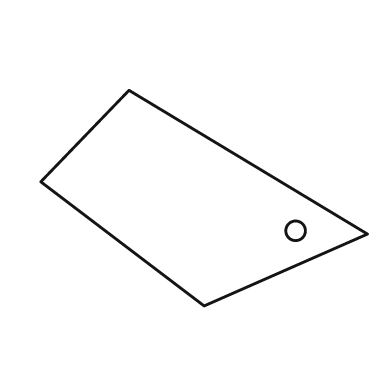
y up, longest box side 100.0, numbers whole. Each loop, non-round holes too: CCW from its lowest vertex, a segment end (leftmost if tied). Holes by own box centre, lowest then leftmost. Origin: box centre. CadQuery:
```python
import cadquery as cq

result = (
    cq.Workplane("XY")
    .moveTo(0.0, -33.0)
    .lineTo(50.0, -11.0)
    .lineTo(-23.0, 33.0)
    .lineTo(-50.0, 5.0)
    .close()
    .moveTo(28.0, -10.0)
    .circle(3.0)
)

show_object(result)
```